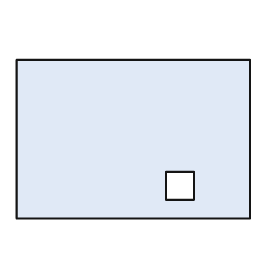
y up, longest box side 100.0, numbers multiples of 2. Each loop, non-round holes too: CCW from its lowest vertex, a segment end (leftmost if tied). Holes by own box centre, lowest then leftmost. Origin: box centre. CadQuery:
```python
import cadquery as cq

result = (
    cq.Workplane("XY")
    .moveTo(-50.0, -34.0)
    .lineTo(50.0, -34.0)
    .lineTo(50.0, 34.0)
    .lineTo(-50.0, 34.0)
    .close()
    .moveTo(14.0, -26.0)
    .lineTo(26.0, -26.0)
    .lineTo(26.0, -14.0)
    .lineTo(14.0, -14.0)
    .close()
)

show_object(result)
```